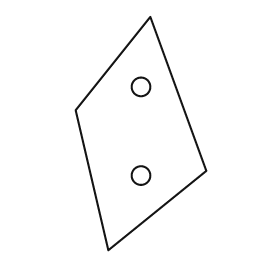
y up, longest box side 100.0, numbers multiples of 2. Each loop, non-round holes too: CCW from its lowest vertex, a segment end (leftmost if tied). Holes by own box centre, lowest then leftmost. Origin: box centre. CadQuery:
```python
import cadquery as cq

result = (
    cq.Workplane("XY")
    .moveTo(-14.0, -50.0)
    .lineTo(28.0, -16.0)
    .lineTo(4.0, 50.0)
    .lineTo(-28.0, 10.0)
    .close()
    .moveTo(0.0, -18.0)
    .circle(4.0)
    .moveTo(0.0, 20.0)
    .circle(4.0)
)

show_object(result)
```